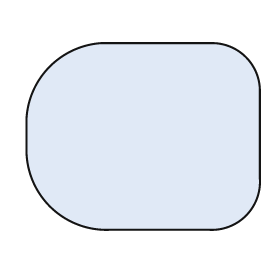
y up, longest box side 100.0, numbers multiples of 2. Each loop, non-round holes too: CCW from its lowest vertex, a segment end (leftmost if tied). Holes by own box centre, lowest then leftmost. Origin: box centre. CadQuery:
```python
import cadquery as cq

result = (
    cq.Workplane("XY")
    .moveTo(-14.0, -40.0)
    .lineTo(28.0, -40.0)
    .threePointArc((44.0, -34.0), (50.0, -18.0))
    .lineTo(50.0, 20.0)
    .threePointArc((44.0, 34.0), (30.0, 40.0))
    .lineTo(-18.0, 40.0)
    .threePointArc((-40.0, 30.0), (-50.0, 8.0))
    .lineTo(-50.0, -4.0)
    .threePointArc((-40.0, -30.0), (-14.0, -40.0))
    .close()
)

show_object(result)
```